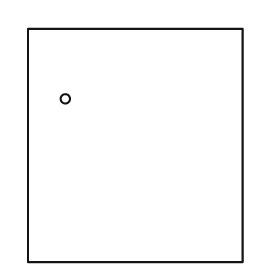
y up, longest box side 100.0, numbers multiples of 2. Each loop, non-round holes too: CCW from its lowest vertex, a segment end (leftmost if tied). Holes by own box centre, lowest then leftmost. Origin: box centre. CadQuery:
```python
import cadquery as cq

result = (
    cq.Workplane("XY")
    .moveTo(-46.0, -50.0)
    .lineTo(46.0, -50.0)
    .lineTo(46.0, 50.0)
    .lineTo(-46.0, 50.0)
    .close()
    .moveTo(-30.0, 20.0)
    .circle(2.0)
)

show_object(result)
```